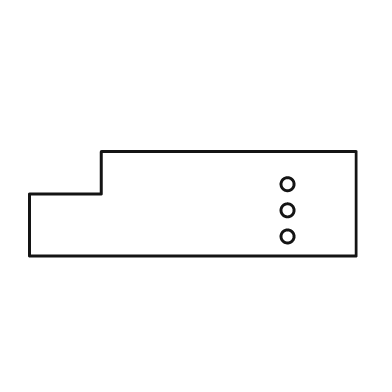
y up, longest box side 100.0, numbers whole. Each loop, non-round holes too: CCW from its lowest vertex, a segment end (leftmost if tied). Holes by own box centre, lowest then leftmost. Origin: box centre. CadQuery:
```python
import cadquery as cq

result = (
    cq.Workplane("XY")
    .moveTo(-50.0, -16.0)
    .lineTo(50.0, -16.0)
    .lineTo(50.0, 16.0)
    .lineTo(-28.0, 16.0)
    .lineTo(-28.0, 3.0)
    .lineTo(-50.0, 3.0)
    .close()
    .moveTo(29.0, -10.0)
    .circle(2.0)
    .moveTo(29.0, -2.0)
    .circle(2.0)
    .moveTo(29.0, 6.0)
    .circle(2.0)
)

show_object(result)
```